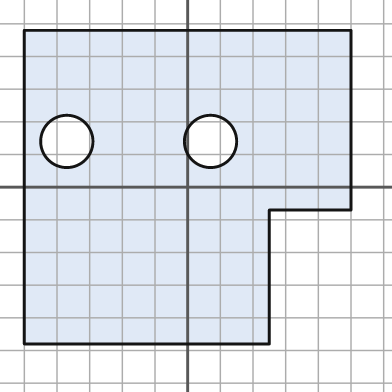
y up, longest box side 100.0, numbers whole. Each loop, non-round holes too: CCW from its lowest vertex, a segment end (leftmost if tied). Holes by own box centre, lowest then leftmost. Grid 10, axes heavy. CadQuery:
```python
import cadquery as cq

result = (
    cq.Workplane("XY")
    .moveTo(-50.0, -48.0)
    .lineTo(25.0, -48.0)
    .lineTo(25.0, -7.0)
    .lineTo(50.0, -7.0)
    .lineTo(50.0, 48.0)
    .lineTo(-50.0, 48.0)
    .close()
    .moveTo(-37.0, 14.0)
    .circle(8.0)
    .moveTo(7.0, 14.0)
    .circle(8.0)
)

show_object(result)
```